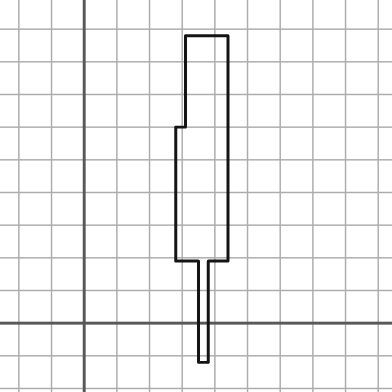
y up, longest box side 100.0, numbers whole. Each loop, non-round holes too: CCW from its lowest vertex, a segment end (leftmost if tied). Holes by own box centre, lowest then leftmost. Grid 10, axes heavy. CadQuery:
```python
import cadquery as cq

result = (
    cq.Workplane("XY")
    .moveTo(35.0, -12.0)
    .lineTo(38.0, -12.0)
    .lineTo(38.0, 19.0)
    .lineTo(44.0, 19.0)
    .lineTo(44.0, 88.0)
    .lineTo(31.0, 88.0)
    .lineTo(31.0, 60.0)
    .lineTo(28.0, 60.0)
    .lineTo(28.0, 19.0)
    .lineTo(35.0, 19.0)
    .close()
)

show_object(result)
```